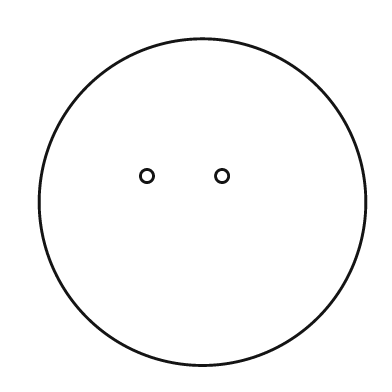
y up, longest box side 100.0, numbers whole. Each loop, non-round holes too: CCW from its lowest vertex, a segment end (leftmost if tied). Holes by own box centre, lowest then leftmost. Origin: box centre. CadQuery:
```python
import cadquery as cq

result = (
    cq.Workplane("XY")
    .moveTo(0.0, 0.0)
    .circle(50.0)
    .moveTo(-17.0, 8.0)
    .circle(2.0)
    .moveTo(6.0, 8.0)
    .circle(2.0)
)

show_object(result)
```